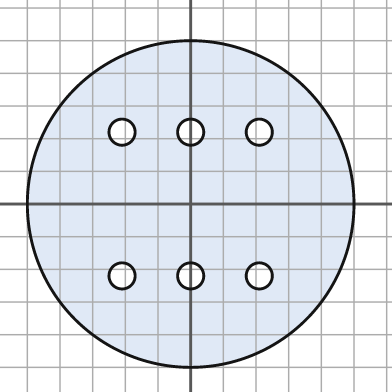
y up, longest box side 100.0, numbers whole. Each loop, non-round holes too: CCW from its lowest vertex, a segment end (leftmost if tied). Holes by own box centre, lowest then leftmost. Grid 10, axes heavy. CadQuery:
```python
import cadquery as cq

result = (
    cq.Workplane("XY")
    .moveTo(0.0, 0.0)
    .circle(50.0)
    .moveTo(-21.0, -22.0)
    .circle(4.0)
    .moveTo(0.0, -22.0)
    .circle(4.0)
    .moveTo(21.0, -22.0)
    .circle(4.0)
    .moveTo(-21.0, 22.0)
    .circle(4.0)
    .moveTo(0.0, 22.0)
    .circle(4.0)
    .moveTo(21.0, 22.0)
    .circle(4.0)
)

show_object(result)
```